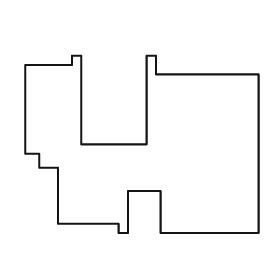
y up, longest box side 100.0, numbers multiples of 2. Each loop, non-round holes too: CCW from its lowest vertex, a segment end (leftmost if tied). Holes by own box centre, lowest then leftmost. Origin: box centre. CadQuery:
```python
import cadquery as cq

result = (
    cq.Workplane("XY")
    .moveTo(-10.0, -38.0)
    .lineTo(-6.0, -38.0)
    .lineTo(-6.0, -20.0)
    .lineTo(8.0, -20.0)
    .lineTo(8.0, -38.0)
    .lineTo(50.0, -38.0)
    .lineTo(50.0, 30.0)
    .lineTo(6.0, 30.0)
    .lineTo(6.0, 38.0)
    .lineTo(2.0, 38.0)
    .lineTo(2.0, 0.0)
    .lineTo(-26.0, 0.0)
    .lineTo(-26.0, 38.0)
    .lineTo(-30.0, 38.0)
    .lineTo(-30.0, 34.0)
    .lineTo(-50.0, 34.0)
    .lineTo(-50.0, -4.0)
    .lineTo(-44.0, -4.0)
    .lineTo(-44.0, -10.0)
    .lineTo(-36.0, -10.0)
    .lineTo(-36.0, -34.0)
    .lineTo(-10.0, -34.0)
    .close()
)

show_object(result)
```